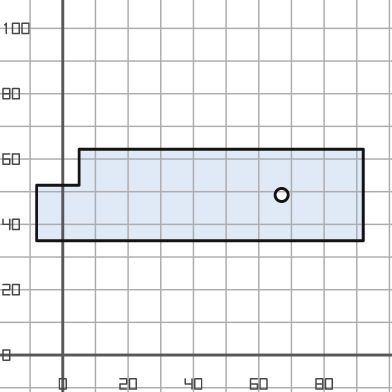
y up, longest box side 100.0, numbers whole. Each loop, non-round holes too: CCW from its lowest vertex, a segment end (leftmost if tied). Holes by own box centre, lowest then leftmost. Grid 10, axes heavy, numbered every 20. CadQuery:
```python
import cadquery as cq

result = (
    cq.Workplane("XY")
    .moveTo(-8.0, 35.0)
    .lineTo(92.0, 35.0)
    .lineTo(92.0, 63.0)
    .lineTo(5.0, 63.0)
    .lineTo(5.0, 52.0)
    .lineTo(-8.0, 52.0)
    .close()
    .moveTo(67.0, 49.0)
    .circle(2.0)
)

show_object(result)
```